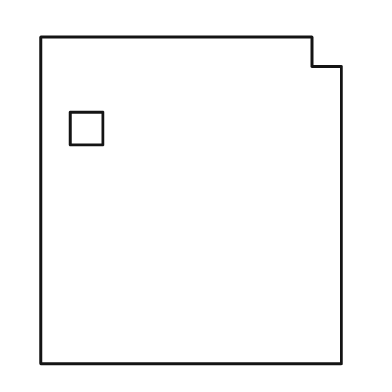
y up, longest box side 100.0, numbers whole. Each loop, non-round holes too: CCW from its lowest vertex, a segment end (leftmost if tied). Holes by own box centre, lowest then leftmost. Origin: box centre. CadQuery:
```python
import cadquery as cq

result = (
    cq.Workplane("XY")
    .moveTo(-46.0, -50.0)
    .lineTo(46.0, -50.0)
    .lineTo(46.0, 41.0)
    .lineTo(37.0, 41.0)
    .lineTo(37.0, 50.0)
    .lineTo(-46.0, 50.0)
    .close()
    .moveTo(-37.0, 17.0)
    .lineTo(-27.0, 17.0)
    .lineTo(-27.0, 27.0)
    .lineTo(-37.0, 27.0)
    .close()
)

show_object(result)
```